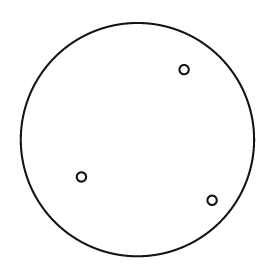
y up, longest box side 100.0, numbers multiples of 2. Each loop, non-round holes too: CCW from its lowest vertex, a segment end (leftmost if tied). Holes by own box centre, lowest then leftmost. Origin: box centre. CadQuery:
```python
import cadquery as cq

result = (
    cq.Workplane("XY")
    .moveTo(0.0, 0.0)
    .circle(50.0)
    .moveTo(32.0, -26.0)
    .circle(2.0)
    .moveTo(-24.0, -16.0)
    .circle(2.0)
    .moveTo(20.0, 30.0)
    .circle(2.0)
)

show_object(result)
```